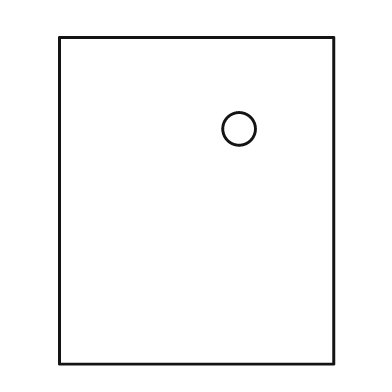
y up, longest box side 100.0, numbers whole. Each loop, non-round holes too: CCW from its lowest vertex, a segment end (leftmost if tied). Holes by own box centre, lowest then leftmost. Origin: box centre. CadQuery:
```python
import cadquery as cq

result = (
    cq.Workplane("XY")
    .moveTo(-42.0, -50.0)
    .lineTo(42.0, -50.0)
    .lineTo(42.0, 50.0)
    .lineTo(-42.0, 50.0)
    .close()
    .moveTo(13.0, 22.0)
    .circle(5.0)
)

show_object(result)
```